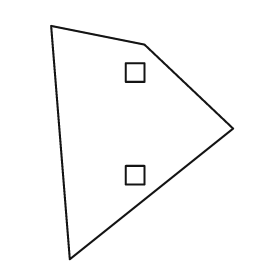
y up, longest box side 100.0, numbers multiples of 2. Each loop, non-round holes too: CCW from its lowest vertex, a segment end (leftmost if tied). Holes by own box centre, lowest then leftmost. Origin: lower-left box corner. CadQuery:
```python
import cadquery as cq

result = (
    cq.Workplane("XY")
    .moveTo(8.0, 0.0)
    .lineTo(78.0, 56.0)
    .lineTo(40.0, 92.0)
    .lineTo(0.0, 100.0)
    .close()
    .moveTo(32.0, 32.0)
    .lineTo(40.0, 32.0)
    .lineTo(40.0, 40.0)
    .lineTo(32.0, 40.0)
    .close()
    .moveTo(32.0, 76.0)
    .lineTo(40.0, 76.0)
    .lineTo(40.0, 84.0)
    .lineTo(32.0, 84.0)
    .close()
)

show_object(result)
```